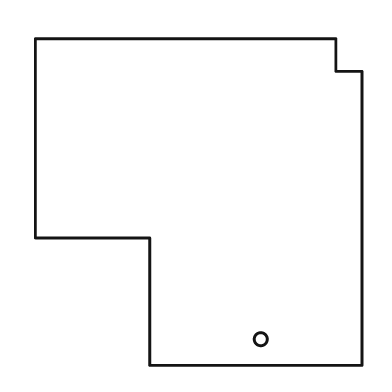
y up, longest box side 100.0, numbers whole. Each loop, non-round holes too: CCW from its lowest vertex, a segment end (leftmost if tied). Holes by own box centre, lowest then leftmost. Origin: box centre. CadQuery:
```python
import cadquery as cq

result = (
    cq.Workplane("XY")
    .moveTo(-15.0, -50.0)
    .lineTo(50.0, -50.0)
    .lineTo(50.0, 40.0)
    .lineTo(42.0, 40.0)
    .lineTo(42.0, 50.0)
    .lineTo(-50.0, 50.0)
    .lineTo(-50.0, -11.0)
    .lineTo(-15.0, -11.0)
    .close()
    .moveTo(19.0, -42.0)
    .circle(2.0)
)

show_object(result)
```